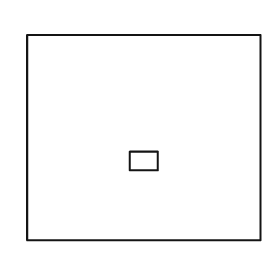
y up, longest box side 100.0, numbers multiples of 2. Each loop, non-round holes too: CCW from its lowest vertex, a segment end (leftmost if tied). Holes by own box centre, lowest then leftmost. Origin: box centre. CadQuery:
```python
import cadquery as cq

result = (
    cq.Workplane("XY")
    .moveTo(-50.0, -44.0)
    .lineTo(50.0, -44.0)
    .lineTo(50.0, 44.0)
    .lineTo(-50.0, 44.0)
    .close()
    .moveTo(-6.0, -14.0)
    .lineTo(6.0, -14.0)
    .lineTo(6.0, -6.0)
    .lineTo(-6.0, -6.0)
    .close()
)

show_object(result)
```